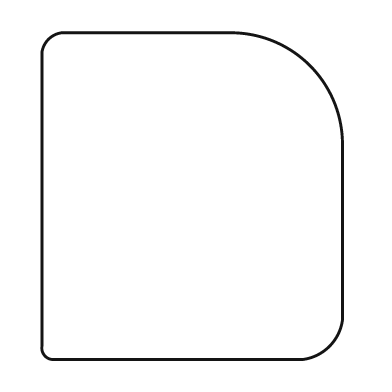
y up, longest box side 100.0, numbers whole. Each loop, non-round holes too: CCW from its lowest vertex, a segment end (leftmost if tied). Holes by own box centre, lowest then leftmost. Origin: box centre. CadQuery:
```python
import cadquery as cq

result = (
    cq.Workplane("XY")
    .moveTo(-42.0, -50.0)
    .lineTo(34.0, -50.0)
    .threePointArc((42.0, -46.0), (46.0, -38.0))
    .lineTo(46.0, 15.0)
    .threePointArc((36.0, 40.0), (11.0, 50.0))
    .lineTo(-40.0, 50.0)
    .threePointArc((-44.0, 48.0), (-46.0, 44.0))
    .lineTo(-46.0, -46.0)
    .threePointArc((-45.0, -49.0), (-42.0, -50.0))
    .close()
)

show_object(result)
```